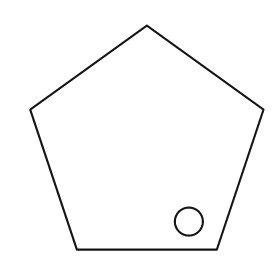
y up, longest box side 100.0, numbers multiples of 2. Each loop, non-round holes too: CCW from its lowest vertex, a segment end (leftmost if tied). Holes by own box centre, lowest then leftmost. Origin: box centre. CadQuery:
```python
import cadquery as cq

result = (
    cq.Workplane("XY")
    .moveTo(-30.0, -48.0)
    .lineTo(30.0, -48.0)
    .lineTo(50.0, 12.0)
    .lineTo(0.0, 48.0)
    .lineTo(-50.0, 12.0)
    .close()
    .moveTo(18.0, -36.0)
    .circle(6.0)
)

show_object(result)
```